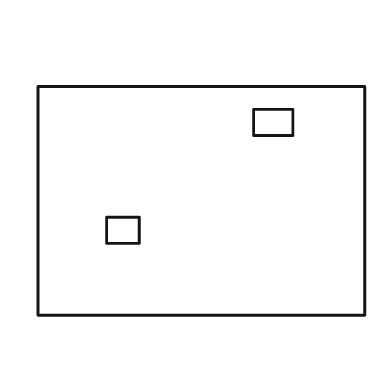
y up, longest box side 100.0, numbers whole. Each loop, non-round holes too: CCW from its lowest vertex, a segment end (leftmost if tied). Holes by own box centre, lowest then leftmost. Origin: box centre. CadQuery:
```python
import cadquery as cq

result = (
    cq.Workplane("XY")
    .moveTo(-50.0, -35.0)
    .lineTo(50.0, -35.0)
    .lineTo(50.0, 35.0)
    .lineTo(-50.0, 35.0)
    .close()
    .moveTo(-29.0, -13.0)
    .lineTo(-19.0, -13.0)
    .lineTo(-19.0, -5.0)
    .lineTo(-29.0, -5.0)
    .close()
    .moveTo(16.0, 20.0)
    .lineTo(28.0, 20.0)
    .lineTo(28.0, 28.0)
    .lineTo(16.0, 28.0)
    .close()
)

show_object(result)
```